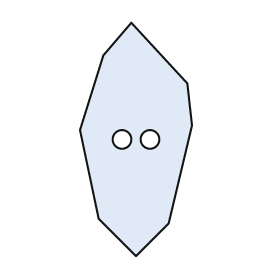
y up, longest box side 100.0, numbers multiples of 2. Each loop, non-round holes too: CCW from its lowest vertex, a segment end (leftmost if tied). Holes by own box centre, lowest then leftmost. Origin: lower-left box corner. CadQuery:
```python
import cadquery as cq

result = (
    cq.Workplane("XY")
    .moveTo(24.0, 0.0)
    .lineTo(38.0, 14.0)
    .lineTo(48.0, 56.0)
    .lineTo(46.0, 74.0)
    .lineTo(22.0, 100.0)
    .lineTo(10.0, 86.0)
    .lineTo(0.0, 54.0)
    .lineTo(8.0, 16.0)
    .close()
    .moveTo(18.0, 50.0)
    .circle(4.0)
    .moveTo(30.0, 50.0)
    .circle(4.0)
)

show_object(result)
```